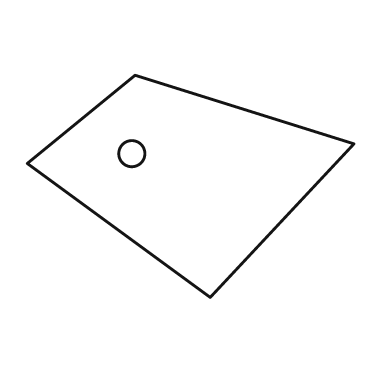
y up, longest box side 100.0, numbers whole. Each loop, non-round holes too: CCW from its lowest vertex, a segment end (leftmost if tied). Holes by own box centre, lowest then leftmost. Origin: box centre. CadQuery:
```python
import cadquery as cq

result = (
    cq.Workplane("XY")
    .moveTo(6.0, -34.0)
    .lineTo(50.0, 13.0)
    .lineTo(-17.0, 34.0)
    .lineTo(-50.0, 7.0)
    .close()
    .moveTo(-18.0, 10.0)
    .circle(4.0)
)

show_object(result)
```